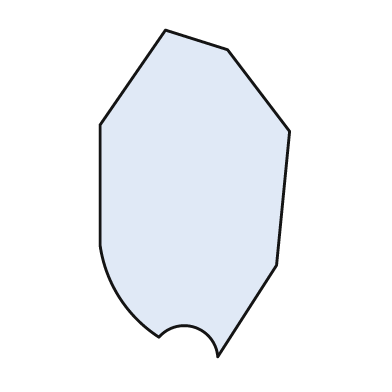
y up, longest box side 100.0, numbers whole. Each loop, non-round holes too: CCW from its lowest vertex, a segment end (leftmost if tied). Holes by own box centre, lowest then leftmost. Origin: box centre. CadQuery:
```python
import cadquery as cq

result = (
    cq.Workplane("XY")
    .moveTo(7.0, -50.0)
    .lineTo(25.0, -22.0)
    .lineTo(29.0, 19.0)
    .lineTo(10.0, 44.0)
    .lineTo(-9.0, 50.0)
    .lineTo(-29.0, 21.0)
    .lineTo(-29.0, -16.0)
    .threePointArc((-23.0, -32.0), (-11.0, -44.0))
    .threePointArc((0.0, -41.0), (7.0, -50.0))
    .close()
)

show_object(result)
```